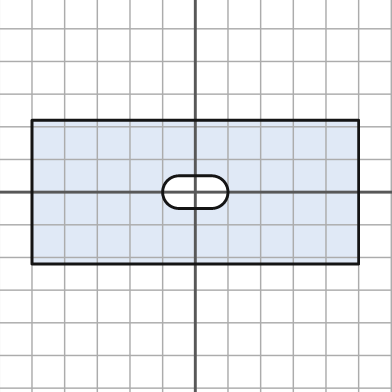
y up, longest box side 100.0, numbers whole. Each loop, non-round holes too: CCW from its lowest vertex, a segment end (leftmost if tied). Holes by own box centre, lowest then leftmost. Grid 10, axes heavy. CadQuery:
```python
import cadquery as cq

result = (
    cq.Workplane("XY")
    .moveTo(-50.0, -22.0)
    .lineTo(50.0, -22.0)
    .lineTo(50.0, 22.0)
    .lineTo(-50.0, 22.0)
    .close()
    .moveTo(-5.0, -5.0)
    .lineTo(5.0, -5.0)
    .threePointArc((10.0, 0.0), (5.0, 5.0))
    .lineTo(-5.0, 5.0)
    .threePointArc((-10.0, 0.0), (-5.0, -5.0))
    .close()
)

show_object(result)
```